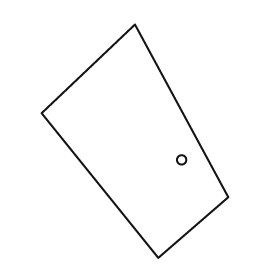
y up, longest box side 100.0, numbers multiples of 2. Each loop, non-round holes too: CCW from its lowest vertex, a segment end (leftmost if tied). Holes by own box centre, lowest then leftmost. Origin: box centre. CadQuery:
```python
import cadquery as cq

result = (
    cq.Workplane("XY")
    .moveTo(10.0, -50.0)
    .lineTo(40.0, -24.0)
    .lineTo(0.0, 50.0)
    .lineTo(-40.0, 12.0)
    .close()
    .moveTo(20.0, -8.0)
    .circle(2.0)
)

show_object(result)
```